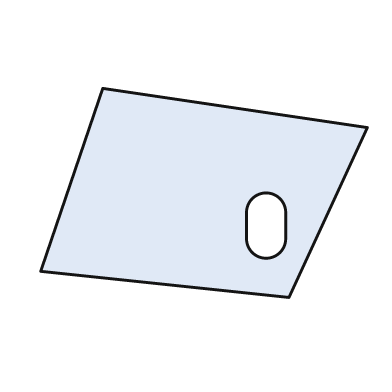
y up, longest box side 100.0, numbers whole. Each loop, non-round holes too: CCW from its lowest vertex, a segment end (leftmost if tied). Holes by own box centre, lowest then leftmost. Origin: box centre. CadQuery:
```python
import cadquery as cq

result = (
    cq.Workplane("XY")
    .moveTo(26.0, -32.0)
    .lineTo(50.0, 20.0)
    .lineTo(-31.0, 32.0)
    .lineTo(-50.0, -24.0)
    .close()
    .moveTo(13.0, -14.0)
    .threePointArc((19.0, -20.0), (25.0, -14.0))
    .lineTo(25.0, -6.0)
    .threePointArc((19.0, 0.0), (13.0, -6.0))
    .close()
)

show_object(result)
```